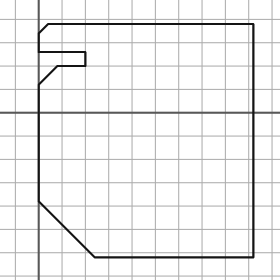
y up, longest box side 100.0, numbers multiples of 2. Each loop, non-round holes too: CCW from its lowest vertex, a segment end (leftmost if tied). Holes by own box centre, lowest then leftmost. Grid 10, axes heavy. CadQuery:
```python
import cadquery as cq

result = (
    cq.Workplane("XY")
    .moveTo(24.0, -62.0)
    .lineTo(92.0, -62.0)
    .lineTo(92.0, 38.0)
    .lineTo(4.0, 38.0)
    .lineTo(0.0, 34.0)
    .lineTo(0.0, 26.0)
    .lineTo(20.0, 26.0)
    .lineTo(20.0, 20.0)
    .lineTo(8.0, 20.0)
    .lineTo(0.0, 12.0)
    .lineTo(0.0, -38.0)
    .close()
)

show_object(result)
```